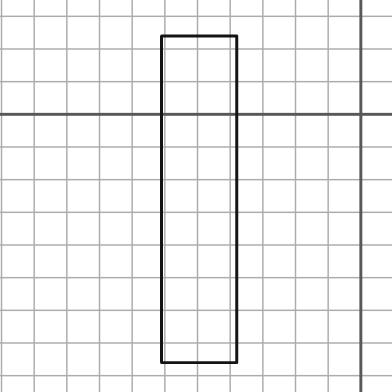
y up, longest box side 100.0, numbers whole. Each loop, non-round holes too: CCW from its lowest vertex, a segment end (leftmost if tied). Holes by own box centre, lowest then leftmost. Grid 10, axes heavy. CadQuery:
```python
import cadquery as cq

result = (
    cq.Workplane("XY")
    .moveTo(-61.0, -76.0)
    .lineTo(-38.0, -76.0)
    .lineTo(-38.0, 24.0)
    .lineTo(-61.0, 24.0)
    .close()
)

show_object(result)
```